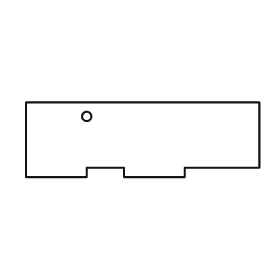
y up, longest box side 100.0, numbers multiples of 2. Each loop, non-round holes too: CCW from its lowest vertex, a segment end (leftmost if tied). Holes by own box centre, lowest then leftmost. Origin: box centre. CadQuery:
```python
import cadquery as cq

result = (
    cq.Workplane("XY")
    .moveTo(-50.0, -16.0)
    .lineTo(-24.0, -16.0)
    .lineTo(-24.0, -12.0)
    .lineTo(-8.0, -12.0)
    .lineTo(-8.0, -16.0)
    .lineTo(18.0, -16.0)
    .lineTo(18.0, -12.0)
    .lineTo(50.0, -12.0)
    .lineTo(50.0, 16.0)
    .lineTo(-50.0, 16.0)
    .close()
    .moveTo(-24.0, 10.0)
    .circle(2.0)
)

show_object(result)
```